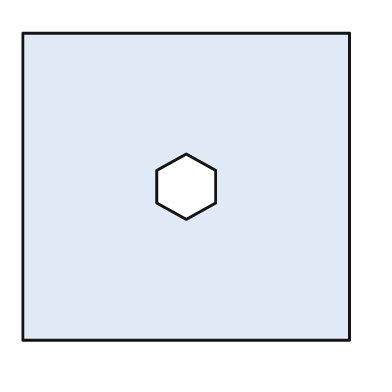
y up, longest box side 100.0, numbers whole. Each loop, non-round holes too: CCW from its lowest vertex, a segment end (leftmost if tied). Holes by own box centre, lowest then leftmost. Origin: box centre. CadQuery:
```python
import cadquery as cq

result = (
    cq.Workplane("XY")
    .moveTo(-50.0, -47.0)
    .lineTo(50.0, -47.0)
    .lineTo(50.0, 47.0)
    .lineTo(-50.0, 47.0)
    .close()
    .moveTo(0.0, -10.0)
    .lineTo(9.0, -5.0)
    .lineTo(9.0, 5.0)
    .lineTo(0.0, 10.0)
    .lineTo(-9.0, 5.0)
    .lineTo(-9.0, -5.0)
    .close()
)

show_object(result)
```